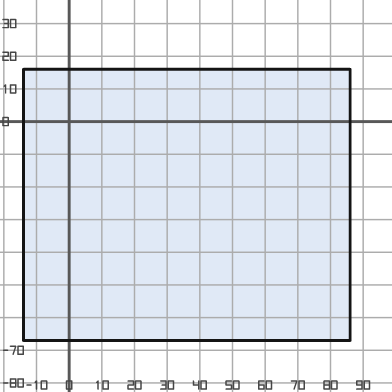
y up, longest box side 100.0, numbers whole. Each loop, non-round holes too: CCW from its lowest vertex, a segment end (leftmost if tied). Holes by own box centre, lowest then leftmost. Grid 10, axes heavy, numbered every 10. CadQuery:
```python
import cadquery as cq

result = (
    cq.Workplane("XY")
    .moveTo(-14.0, -67.0)
    .lineTo(86.0, -67.0)
    .lineTo(86.0, 16.0)
    .lineTo(-14.0, 16.0)
    .close()
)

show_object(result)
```